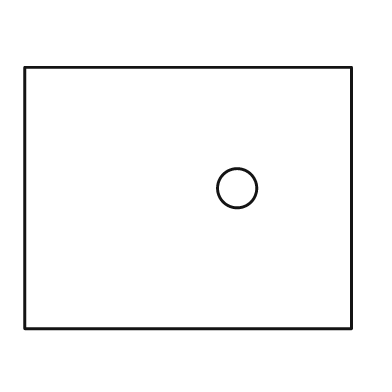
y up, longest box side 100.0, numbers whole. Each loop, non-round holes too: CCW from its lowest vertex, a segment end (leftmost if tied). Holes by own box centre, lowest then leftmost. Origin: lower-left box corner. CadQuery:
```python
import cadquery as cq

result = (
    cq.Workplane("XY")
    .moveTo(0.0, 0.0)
    .lineTo(100.0, 0.0)
    .lineTo(100.0, 80.0)
    .lineTo(0.0, 80.0)
    .close()
    .moveTo(65.0, 43.0)
    .circle(6.0)
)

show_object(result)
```